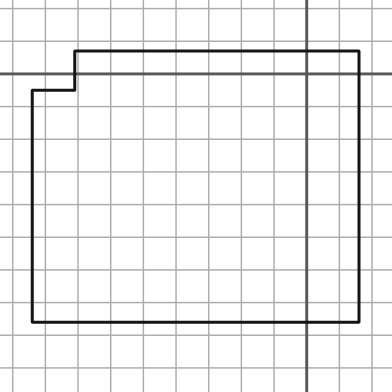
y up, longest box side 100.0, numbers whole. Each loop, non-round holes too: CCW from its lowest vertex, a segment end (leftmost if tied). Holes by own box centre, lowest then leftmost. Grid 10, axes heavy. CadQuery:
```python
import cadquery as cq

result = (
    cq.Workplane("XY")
    .moveTo(-84.0, -76.0)
    .lineTo(16.0, -76.0)
    .lineTo(16.0, 7.0)
    .lineTo(-71.0, 7.0)
    .lineTo(-71.0, -5.0)
    .lineTo(-84.0, -5.0)
    .close()
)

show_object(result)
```